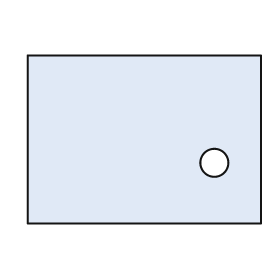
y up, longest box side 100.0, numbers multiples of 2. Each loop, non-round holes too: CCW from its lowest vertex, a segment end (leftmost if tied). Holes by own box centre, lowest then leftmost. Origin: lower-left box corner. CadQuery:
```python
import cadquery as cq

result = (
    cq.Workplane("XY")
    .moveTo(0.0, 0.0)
    .lineTo(100.0, 0.0)
    .lineTo(100.0, 72.0)
    .lineTo(0.0, 72.0)
    .close()
    .moveTo(80.0, 26.0)
    .circle(6.0)
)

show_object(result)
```